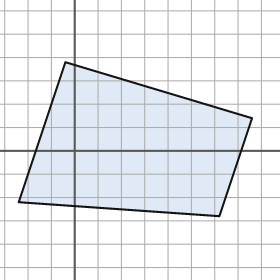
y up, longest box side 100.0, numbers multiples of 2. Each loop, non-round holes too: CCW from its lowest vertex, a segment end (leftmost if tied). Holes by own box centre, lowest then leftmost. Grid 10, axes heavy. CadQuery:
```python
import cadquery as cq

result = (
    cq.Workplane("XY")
    .moveTo(62.0, -28.0)
    .lineTo(76.0, 14.0)
    .lineTo(-4.0, 38.0)
    .lineTo(-24.0, -22.0)
    .close()
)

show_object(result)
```